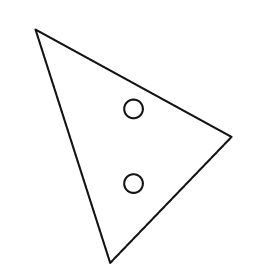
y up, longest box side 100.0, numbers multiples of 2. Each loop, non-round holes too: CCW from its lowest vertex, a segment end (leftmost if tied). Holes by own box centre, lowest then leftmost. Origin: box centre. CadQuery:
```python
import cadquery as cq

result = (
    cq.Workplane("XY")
    .moveTo(-10.0, -50.0)
    .lineTo(42.0, 4.0)
    .lineTo(-42.0, 50.0)
    .close()
    .moveTo(0.0, -16.0)
    .circle(4.0)
    .moveTo(0.0, 16.0)
    .circle(4.0)
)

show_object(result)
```